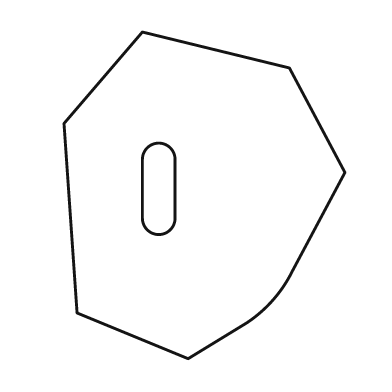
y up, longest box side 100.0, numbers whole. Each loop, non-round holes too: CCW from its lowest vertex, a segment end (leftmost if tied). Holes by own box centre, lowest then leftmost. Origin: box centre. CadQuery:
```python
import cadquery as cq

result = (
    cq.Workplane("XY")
    .moveTo(-5.0, -50.0)
    .lineTo(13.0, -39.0)
    .threePointArc((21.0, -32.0), (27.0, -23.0))
    .lineTo(43.0, 7.0)
    .lineTo(26.0, 39.0)
    .lineTo(-19.0, 50.0)
    .lineTo(-43.0, 22.0)
    .lineTo(-39.0, -36.0)
    .close()
    .moveTo(-19.0, -7.0)
    .threePointArc((-14.0, -12.0), (-9.0, -7.0))
    .lineTo(-9.0, 11.0)
    .threePointArc((-14.0, 16.0), (-19.0, 11.0))
    .close()
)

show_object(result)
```